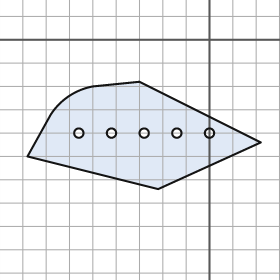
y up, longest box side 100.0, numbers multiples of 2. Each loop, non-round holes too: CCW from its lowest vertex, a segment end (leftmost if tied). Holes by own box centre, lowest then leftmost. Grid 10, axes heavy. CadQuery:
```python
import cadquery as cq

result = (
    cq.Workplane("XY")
    .moveTo(-22.0, -64.0)
    .lineTo(22.0, -44.0)
    .lineTo(-30.0, -18.0)
    .lineTo(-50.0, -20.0)
    .threePointArc((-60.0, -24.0), (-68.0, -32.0))
    .lineTo(-78.0, -50.0)
    .close()
    .moveTo(-56.0, -40.0)
    .circle(2.0)
    .moveTo(-42.0, -40.0)
    .circle(2.0)
    .moveTo(-28.0, -40.0)
    .circle(2.0)
    .moveTo(-14.0, -40.0)
    .circle(2.0)
    .moveTo(0.0, -40.0)
    .circle(2.0)
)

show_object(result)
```